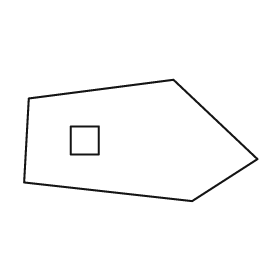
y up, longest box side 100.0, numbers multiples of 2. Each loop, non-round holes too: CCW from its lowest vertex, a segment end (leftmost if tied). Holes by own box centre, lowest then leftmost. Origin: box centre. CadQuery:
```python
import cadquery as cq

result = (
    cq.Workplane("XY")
    .moveTo(22.0, -26.0)
    .lineTo(50.0, -8.0)
    .lineTo(14.0, 26.0)
    .lineTo(-48.0, 18.0)
    .lineTo(-50.0, -18.0)
    .close()
    .moveTo(-30.0, -6.0)
    .lineTo(-18.0, -6.0)
    .lineTo(-18.0, 6.0)
    .lineTo(-30.0, 6.0)
    .close()
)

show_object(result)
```